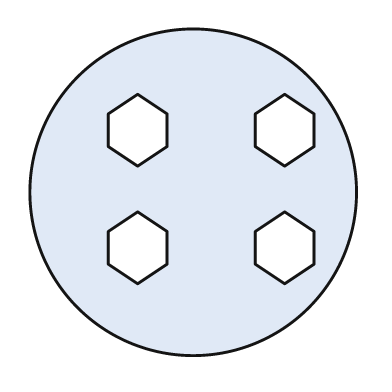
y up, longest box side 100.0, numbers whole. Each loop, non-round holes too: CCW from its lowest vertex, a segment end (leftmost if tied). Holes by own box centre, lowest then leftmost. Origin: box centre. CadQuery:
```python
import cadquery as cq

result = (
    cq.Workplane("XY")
    .moveTo(0.0, 0.0)
    .circle(50.0)
    .moveTo(-17.0, -28.0)
    .lineTo(-8.0, -22.0)
    .lineTo(-8.0, -12.0)
    .lineTo(-17.0, -6.0)
    .lineTo(-26.0, -12.0)
    .lineTo(-26.0, -22.0)
    .close()
    .moveTo(28.0, -28.0)
    .lineTo(37.0, -22.0)
    .lineTo(37.0, -12.0)
    .lineTo(28.0, -6.0)
    .lineTo(19.0, -12.0)
    .lineTo(19.0, -22.0)
    .close()
    .moveTo(-17.0, 8.0)
    .lineTo(-8.0, 14.0)
    .lineTo(-8.0, 24.0)
    .lineTo(-17.0, 30.0)
    .lineTo(-26.0, 24.0)
    .lineTo(-26.0, 14.0)
    .close()
    .moveTo(28.0, 8.0)
    .lineTo(37.0, 14.0)
    .lineTo(37.0, 24.0)
    .lineTo(28.0, 30.0)
    .lineTo(19.0, 24.0)
    .lineTo(19.0, 14.0)
    .close()
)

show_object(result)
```